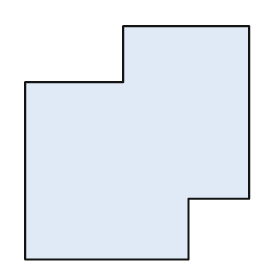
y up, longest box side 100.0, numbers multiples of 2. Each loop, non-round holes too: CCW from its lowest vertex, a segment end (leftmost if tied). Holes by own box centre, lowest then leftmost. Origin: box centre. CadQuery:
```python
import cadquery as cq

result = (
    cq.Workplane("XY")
    .moveTo(-48.0, -50.0)
    .lineTo(22.0, -50.0)
    .lineTo(22.0, -24.0)
    .lineTo(48.0, -24.0)
    .lineTo(48.0, 50.0)
    .lineTo(-6.0, 50.0)
    .lineTo(-6.0, 26.0)
    .lineTo(-48.0, 26.0)
    .close()
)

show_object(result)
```